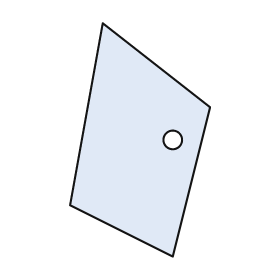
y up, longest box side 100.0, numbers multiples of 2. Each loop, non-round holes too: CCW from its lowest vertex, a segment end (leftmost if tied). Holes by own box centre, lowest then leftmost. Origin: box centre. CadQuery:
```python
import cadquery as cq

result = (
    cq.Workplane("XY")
    .moveTo(14.0, -50.0)
    .lineTo(30.0, 14.0)
    .lineTo(-16.0, 50.0)
    .lineTo(-30.0, -28.0)
    .close()
    .moveTo(14.0, 0.0)
    .circle(4.0)
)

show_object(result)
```